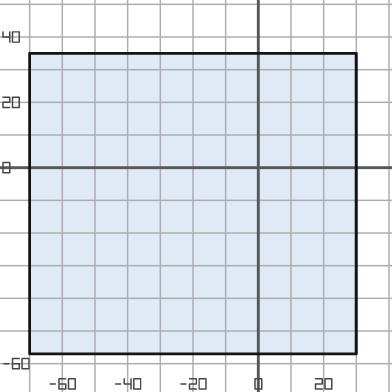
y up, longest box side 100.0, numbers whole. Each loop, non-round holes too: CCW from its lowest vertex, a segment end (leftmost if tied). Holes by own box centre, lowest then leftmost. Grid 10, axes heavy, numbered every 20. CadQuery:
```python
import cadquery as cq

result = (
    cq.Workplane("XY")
    .moveTo(-70.0, -57.0)
    .lineTo(30.0, -57.0)
    .lineTo(30.0, 35.0)
    .lineTo(-70.0, 35.0)
    .close()
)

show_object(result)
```